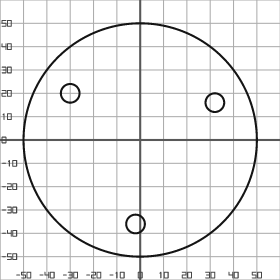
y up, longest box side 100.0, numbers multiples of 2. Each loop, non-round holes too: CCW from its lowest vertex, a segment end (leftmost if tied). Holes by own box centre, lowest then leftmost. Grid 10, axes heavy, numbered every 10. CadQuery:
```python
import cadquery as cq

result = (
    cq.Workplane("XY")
    .moveTo(0.0, 0.0)
    .circle(50.0)
    .moveTo(-2.0, -36.0)
    .circle(4.0)
    .moveTo(32.0, 16.0)
    .circle(4.0)
    .moveTo(-30.0, 20.0)
    .circle(4.0)
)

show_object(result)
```